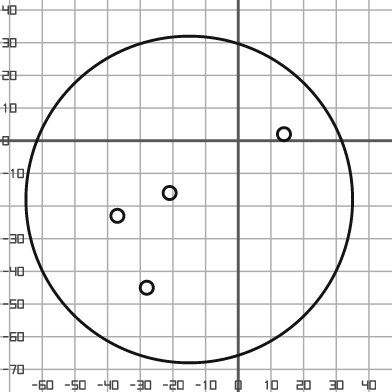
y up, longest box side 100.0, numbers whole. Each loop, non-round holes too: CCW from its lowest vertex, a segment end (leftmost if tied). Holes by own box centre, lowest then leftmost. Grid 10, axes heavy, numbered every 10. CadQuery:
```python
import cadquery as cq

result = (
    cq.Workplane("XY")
    .moveTo(-15.0, -18.0)
    .circle(50.0)
    .moveTo(-28.0, -45.0)
    .circle(2.0)
    .moveTo(-37.0, -23.0)
    .circle(2.0)
    .moveTo(-21.0, -16.0)
    .circle(2.0)
    .moveTo(14.0, 2.0)
    .circle(2.0)
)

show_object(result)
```